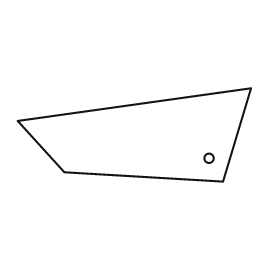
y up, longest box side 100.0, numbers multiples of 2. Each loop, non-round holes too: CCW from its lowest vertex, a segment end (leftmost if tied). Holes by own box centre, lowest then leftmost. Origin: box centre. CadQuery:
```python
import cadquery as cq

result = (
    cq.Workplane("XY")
    .moveTo(38.0, -20.0)
    .lineTo(50.0, 20.0)
    .lineTo(-50.0, 6.0)
    .lineTo(-30.0, -16.0)
    .close()
    .moveTo(32.0, -10.0)
    .circle(2.0)
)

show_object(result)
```